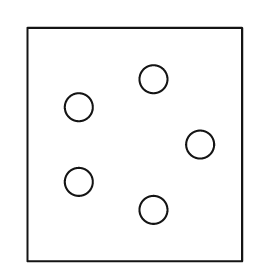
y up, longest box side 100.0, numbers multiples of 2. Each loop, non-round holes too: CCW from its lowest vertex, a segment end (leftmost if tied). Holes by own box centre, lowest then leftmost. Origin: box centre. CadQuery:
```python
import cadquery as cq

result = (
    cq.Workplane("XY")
    .moveTo(-46.0, -50.0)
    .lineTo(46.0, -50.0)
    .lineTo(46.0, 50.0)
    .lineTo(-46.0, 50.0)
    .close()
    .moveTo(8.0, -28.0)
    .circle(6.0)
    .moveTo(-24.0, -16.0)
    .circle(6.0)
    .moveTo(28.0, 0.0)
    .circle(6.0)
    .moveTo(-24.0, 16.0)
    .circle(6.0)
    .moveTo(8.0, 28.0)
    .circle(6.0)
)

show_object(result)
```